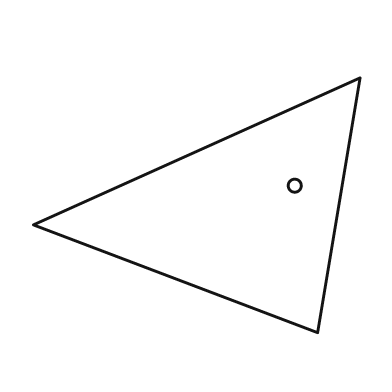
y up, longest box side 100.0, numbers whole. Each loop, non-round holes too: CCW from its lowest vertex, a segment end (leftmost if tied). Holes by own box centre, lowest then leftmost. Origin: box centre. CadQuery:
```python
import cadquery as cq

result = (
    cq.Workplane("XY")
    .moveTo(37.0, -39.0)
    .lineTo(50.0, 39.0)
    .lineTo(-50.0, -6.0)
    .close()
    .moveTo(30.0, 6.0)
    .circle(2.0)
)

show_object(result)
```